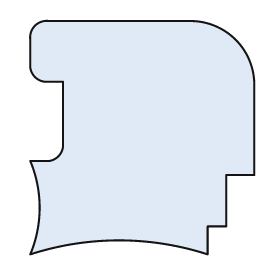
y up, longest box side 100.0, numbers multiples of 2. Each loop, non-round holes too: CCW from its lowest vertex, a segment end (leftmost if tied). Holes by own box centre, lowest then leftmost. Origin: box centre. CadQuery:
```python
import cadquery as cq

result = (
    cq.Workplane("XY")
    .moveTo(-48.0, -50.0)
    .threePointArc((-10.0, -44.0), (28.0, -50.0))
    .lineTo(28.0, -38.0)
    .lineTo(36.0, -38.0)
    .lineTo(36.0, -16.0)
    .lineTo(48.0, -16.0)
    .lineTo(48.0, 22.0)
    .threePointArc((40.0, 42.0), (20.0, 50.0))
    .lineTo(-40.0, 50.0)
    .threePointArc((-46.0, 48.0), (-48.0, 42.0))
    .lineTo(-48.0, 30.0)
    .threePointArc((-46.0, 26.0), (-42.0, 24.0))
    .lineTo(-34.0, 24.0)
    .lineTo(-34.0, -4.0)
    .threePointArc((-36.0, -8.0), (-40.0, -10.0))
    .lineTo(-48.0, -10.0)
    .threePointArc((-44.0, -30.0), (-48.0, -50.0))
    .close()
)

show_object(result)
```